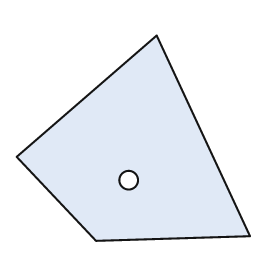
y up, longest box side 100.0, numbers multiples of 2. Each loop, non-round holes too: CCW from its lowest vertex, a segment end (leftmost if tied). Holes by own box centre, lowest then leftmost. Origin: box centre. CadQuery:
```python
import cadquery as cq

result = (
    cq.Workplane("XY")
    .moveTo(-16.0, -44.0)
    .lineTo(50.0, -42.0)
    .lineTo(10.0, 44.0)
    .lineTo(-50.0, -8.0)
    .close()
    .moveTo(-2.0, -18.0)
    .circle(4.0)
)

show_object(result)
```